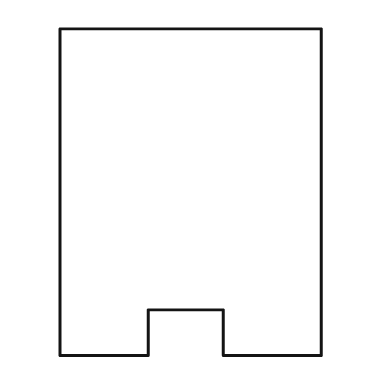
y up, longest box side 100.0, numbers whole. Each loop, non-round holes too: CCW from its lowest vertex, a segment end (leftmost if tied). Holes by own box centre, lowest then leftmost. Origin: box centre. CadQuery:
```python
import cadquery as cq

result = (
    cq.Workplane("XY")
    .moveTo(-40.0, -50.0)
    .lineTo(-13.0, -50.0)
    .lineTo(-13.0, -36.0)
    .lineTo(10.0, -36.0)
    .lineTo(10.0, -50.0)
    .lineTo(40.0, -50.0)
    .lineTo(40.0, 50.0)
    .lineTo(-40.0, 50.0)
    .close()
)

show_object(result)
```